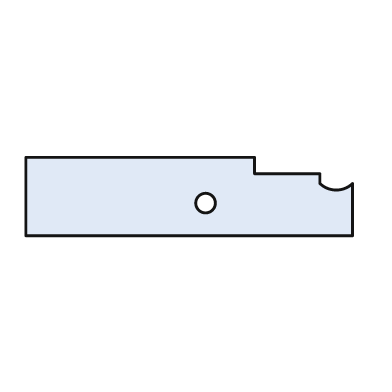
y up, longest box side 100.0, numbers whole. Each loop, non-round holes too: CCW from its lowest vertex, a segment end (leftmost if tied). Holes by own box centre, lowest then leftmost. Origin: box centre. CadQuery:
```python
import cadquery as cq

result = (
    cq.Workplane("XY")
    .moveTo(-50.0, -12.0)
    .lineTo(50.0, -12.0)
    .lineTo(50.0, 4.0)
    .threePointArc((45.0, 2.0), (40.0, 4.0))
    .lineTo(40.0, 7.0)
    .lineTo(20.0, 7.0)
    .lineTo(20.0, 12.0)
    .lineTo(-50.0, 12.0)
    .close()
    .moveTo(5.0, -2.0)
    .circle(3.0)
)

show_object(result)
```